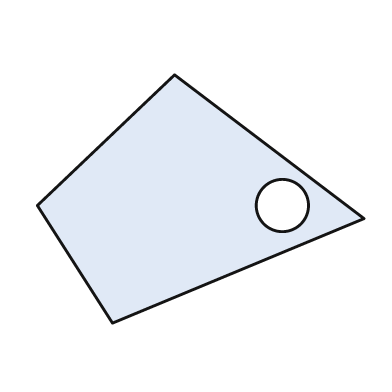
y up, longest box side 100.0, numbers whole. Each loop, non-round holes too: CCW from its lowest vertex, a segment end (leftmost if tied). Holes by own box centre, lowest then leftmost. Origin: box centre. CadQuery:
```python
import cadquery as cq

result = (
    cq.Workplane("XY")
    .moveTo(-27.0, -38.0)
    .lineTo(50.0, -6.0)
    .lineTo(-8.0, 38.0)
    .lineTo(-50.0, -2.0)
    .close()
    .moveTo(25.0, -2.0)
    .circle(8.0)
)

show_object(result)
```